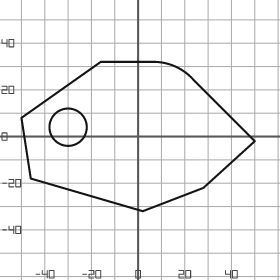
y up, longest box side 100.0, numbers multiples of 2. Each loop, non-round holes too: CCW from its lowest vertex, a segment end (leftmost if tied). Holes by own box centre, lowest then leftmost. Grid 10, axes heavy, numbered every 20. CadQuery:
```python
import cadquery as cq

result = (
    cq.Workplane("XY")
    .moveTo(2.0, -32.0)
    .lineTo(28.0, -22.0)
    .lineTo(50.0, -2.0)
    .lineTo(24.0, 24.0)
    .threePointArc((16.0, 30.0), (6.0, 32.0))
    .lineTo(-16.0, 32.0)
    .lineTo(-50.0, 8.0)
    .lineTo(-46.0, -18.0)
    .close()
    .moveTo(-30.0, 4.0)
    .circle(8.0)
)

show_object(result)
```